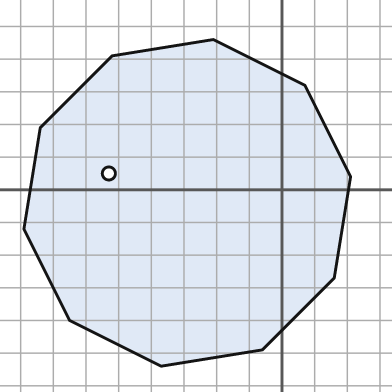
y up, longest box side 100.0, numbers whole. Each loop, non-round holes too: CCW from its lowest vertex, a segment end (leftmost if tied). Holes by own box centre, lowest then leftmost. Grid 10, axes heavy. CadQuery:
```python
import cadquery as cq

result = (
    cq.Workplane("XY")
    .moveTo(-37.0, -54.0)
    .lineTo(-6.0, -49.0)
    .lineTo(16.0, -27.0)
    .lineTo(21.0, 4.0)
    .lineTo(7.0, 32.0)
    .lineTo(-21.0, 46.0)
    .lineTo(-52.0, 41.0)
    .lineTo(-74.0, 19.0)
    .lineTo(-79.0, -12.0)
    .lineTo(-65.0, -40.0)
    .close()
    .moveTo(-53.0, 5.0)
    .circle(2.0)
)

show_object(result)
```